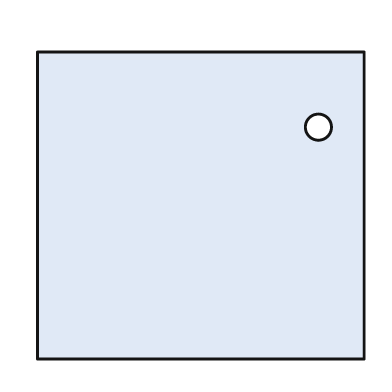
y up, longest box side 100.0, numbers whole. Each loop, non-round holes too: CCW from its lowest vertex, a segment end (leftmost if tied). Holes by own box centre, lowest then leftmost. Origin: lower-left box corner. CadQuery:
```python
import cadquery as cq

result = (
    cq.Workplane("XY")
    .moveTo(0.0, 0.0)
    .lineTo(100.0, 0.0)
    .lineTo(100.0, 94.0)
    .lineTo(0.0, 94.0)
    .close()
    .moveTo(86.0, 71.0)
    .circle(4.0)
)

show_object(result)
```